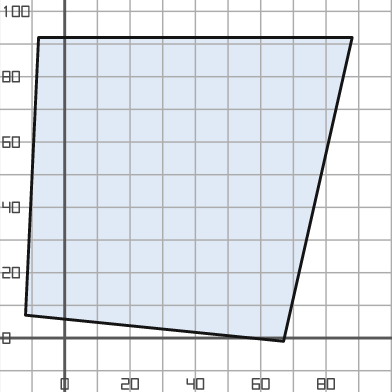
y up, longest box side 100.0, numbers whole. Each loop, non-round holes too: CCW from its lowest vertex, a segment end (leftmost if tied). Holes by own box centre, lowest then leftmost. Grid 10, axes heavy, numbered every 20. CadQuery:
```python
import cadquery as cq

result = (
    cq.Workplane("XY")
    .moveTo(67.0, -1.0)
    .lineTo(88.0, 92.0)
    .lineTo(-8.0, 92.0)
    .lineTo(-12.0, 7.0)
    .close()
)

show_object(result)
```